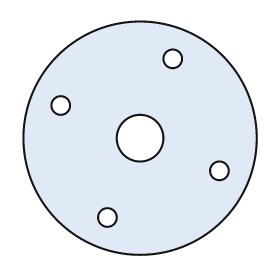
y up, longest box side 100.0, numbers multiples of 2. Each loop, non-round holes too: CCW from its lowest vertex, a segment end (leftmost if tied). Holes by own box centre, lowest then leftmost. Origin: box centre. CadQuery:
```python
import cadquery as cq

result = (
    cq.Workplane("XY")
    .moveTo(0.0, 0.0)
    .circle(50.0)
    .moveTo(-14.0, -34.0)
    .circle(4.0)
    .moveTo(34.0, -14.0)
    .circle(4.0)
    .moveTo(0.0, 0.0)
    .circle(10.0)
    .moveTo(-34.0, 14.0)
    .circle(4.0)
    .moveTo(14.0, 34.0)
    .circle(4.0)
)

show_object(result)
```